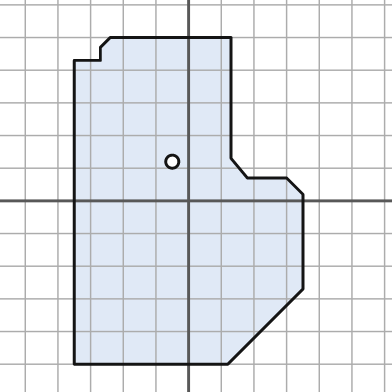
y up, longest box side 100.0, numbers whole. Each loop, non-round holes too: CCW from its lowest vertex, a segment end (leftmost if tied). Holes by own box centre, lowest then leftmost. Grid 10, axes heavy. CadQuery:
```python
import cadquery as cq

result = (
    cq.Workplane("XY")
    .moveTo(-35.0, -50.0)
    .lineTo(12.0, -50.0)
    .lineTo(35.0, -27.0)
    .lineTo(35.0, 2.0)
    .lineTo(30.0, 7.0)
    .lineTo(18.0, 7.0)
    .lineTo(13.0, 13.0)
    .lineTo(13.0, 50.0)
    .lineTo(-24.0, 50.0)
    .lineTo(-27.0, 47.0)
    .lineTo(-27.0, 43.0)
    .lineTo(-35.0, 43.0)
    .close()
    .moveTo(-5.0, 12.0)
    .circle(2.0)
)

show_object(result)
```